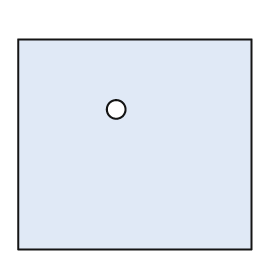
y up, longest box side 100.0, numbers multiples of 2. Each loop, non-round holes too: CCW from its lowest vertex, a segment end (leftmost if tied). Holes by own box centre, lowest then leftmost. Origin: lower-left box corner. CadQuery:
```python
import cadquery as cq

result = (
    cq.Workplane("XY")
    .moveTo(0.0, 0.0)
    .lineTo(100.0, 0.0)
    .lineTo(100.0, 90.0)
    .lineTo(0.0, 90.0)
    .close()
    .moveTo(42.0, 60.0)
    .circle(4.0)
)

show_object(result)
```